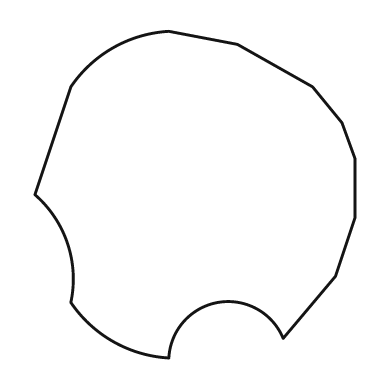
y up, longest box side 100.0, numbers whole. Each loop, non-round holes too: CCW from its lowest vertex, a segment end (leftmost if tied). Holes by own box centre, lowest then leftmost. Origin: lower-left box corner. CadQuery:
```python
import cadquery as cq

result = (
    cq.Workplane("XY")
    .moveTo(41.0, 0.0)
    .threePointArc((56.0, 17.0), (76.0, 6.0))
    .lineTo(92.0, 25.0)
    .lineTo(98.0, 43.0)
    .lineTo(98.0, 61.0)
    .lineTo(94.0, 72.0)
    .lineTo(85.0, 83.0)
    .lineTo(62.0, 96.0)
    .lineTo(41.0, 100.0)
    .threePointArc((24.0, 95.0), (11.0, 83.0))
    .lineTo(0.0, 50.0)
    .threePointArc((10.0, 35.0), (11.0, 17.0))
    .threePointArc((24.0, 5.0), (41.0, 0.0))
    .close()
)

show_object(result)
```